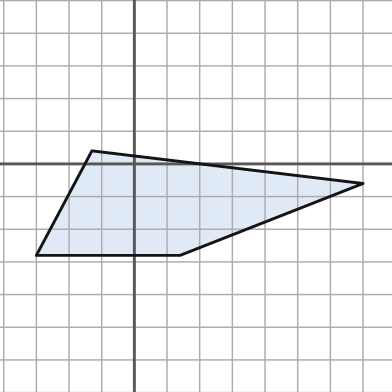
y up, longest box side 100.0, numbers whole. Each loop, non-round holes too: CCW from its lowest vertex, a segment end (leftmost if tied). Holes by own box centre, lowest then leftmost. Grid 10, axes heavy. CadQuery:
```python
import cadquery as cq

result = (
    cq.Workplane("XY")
    .moveTo(-30.0, -28.0)
    .lineTo(14.0, -28.0)
    .lineTo(70.0, -6.0)
    .lineTo(-13.0, 4.0)
    .close()
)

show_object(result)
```